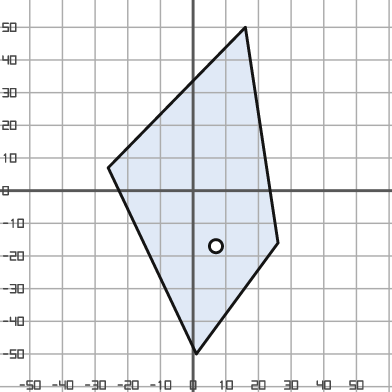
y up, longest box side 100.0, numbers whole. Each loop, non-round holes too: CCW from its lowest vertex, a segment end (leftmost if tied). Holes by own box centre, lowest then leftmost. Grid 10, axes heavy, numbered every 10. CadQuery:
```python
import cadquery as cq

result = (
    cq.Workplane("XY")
    .moveTo(1.0, -50.0)
    .lineTo(26.0, -16.0)
    .lineTo(16.0, 50.0)
    .lineTo(-26.0, 7.0)
    .close()
    .moveTo(7.0, -17.0)
    .circle(2.0)
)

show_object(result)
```